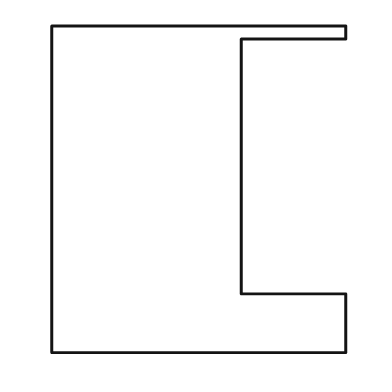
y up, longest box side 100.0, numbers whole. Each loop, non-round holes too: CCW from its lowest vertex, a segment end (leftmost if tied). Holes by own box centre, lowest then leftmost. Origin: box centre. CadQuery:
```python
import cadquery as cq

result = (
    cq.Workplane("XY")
    .moveTo(-45.0, -50.0)
    .lineTo(45.0, -50.0)
    .lineTo(45.0, -32.0)
    .lineTo(13.0, -32.0)
    .lineTo(13.0, 46.0)
    .lineTo(45.0, 46.0)
    .lineTo(45.0, 50.0)
    .lineTo(-45.0, 50.0)
    .close()
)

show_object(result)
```